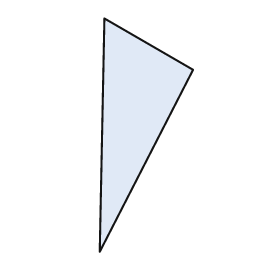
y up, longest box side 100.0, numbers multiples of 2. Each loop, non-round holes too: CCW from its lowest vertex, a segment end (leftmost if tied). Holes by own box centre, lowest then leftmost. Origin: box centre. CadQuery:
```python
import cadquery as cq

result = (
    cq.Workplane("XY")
    .moveTo(-20.0, -50.0)
    .lineTo(20.0, 28.0)
    .lineTo(-18.0, 50.0)
    .close()
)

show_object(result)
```